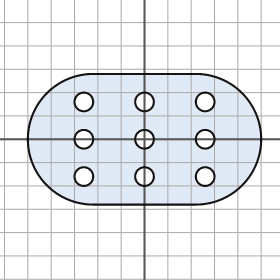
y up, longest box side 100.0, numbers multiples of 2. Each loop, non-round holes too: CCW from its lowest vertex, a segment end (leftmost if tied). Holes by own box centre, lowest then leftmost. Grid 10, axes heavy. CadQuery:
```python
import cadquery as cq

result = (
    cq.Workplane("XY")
    .moveTo(-22.0, -28.0)
    .lineTo(22.0, -28.0)
    .threePointArc((50.0, 0.0), (22.0, 28.0))
    .lineTo(-22.0, 28.0)
    .threePointArc((-50.0, 0.0), (-22.0, -28.0))
    .close()
    .moveTo(-26.0, -16.0)
    .circle(4.0)
    .moveTo(0.0, -16.0)
    .circle(4.0)
    .moveTo(26.0, -16.0)
    .circle(4.0)
    .moveTo(-26.0, 0.0)
    .circle(4.0)
    .moveTo(0.0, 0.0)
    .circle(4.0)
    .moveTo(26.0, 0.0)
    .circle(4.0)
    .moveTo(-26.0, 16.0)
    .circle(4.0)
    .moveTo(0.0, 16.0)
    .circle(4.0)
    .moveTo(26.0, 16.0)
    .circle(4.0)
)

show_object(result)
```